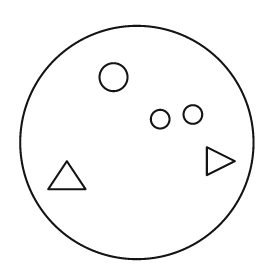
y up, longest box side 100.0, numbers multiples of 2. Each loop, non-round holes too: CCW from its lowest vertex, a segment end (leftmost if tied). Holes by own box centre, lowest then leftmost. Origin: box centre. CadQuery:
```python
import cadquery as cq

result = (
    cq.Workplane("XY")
    .moveTo(0.0, 0.0)
    .circle(50.0)
    .moveTo(-38.0, -20.0)
    .lineTo(-22.0, -20.0)
    .lineTo(-30.0, -8.0)
    .close()
    .moveTo(30.0, -14.0)
    .lineTo(42.0, -8.0)
    .lineTo(30.0, -2.0)
    .close()
    .moveTo(10.0, 10.0)
    .circle(4.0)
    .moveTo(24.0, 12.0)
    .circle(4.0)
    .moveTo(-10.0, 28.0)
    .circle(6.0)
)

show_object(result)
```